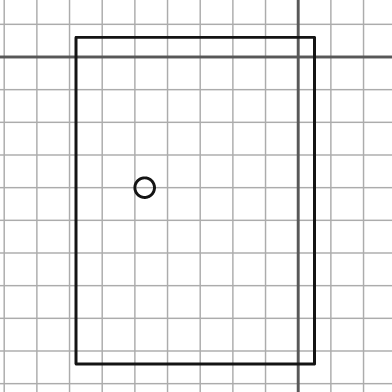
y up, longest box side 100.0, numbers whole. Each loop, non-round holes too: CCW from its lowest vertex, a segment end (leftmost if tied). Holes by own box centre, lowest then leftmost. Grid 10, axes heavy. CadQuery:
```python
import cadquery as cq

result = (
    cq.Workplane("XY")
    .moveTo(-68.0, -94.0)
    .lineTo(5.0, -94.0)
    .lineTo(5.0, 6.0)
    .lineTo(-68.0, 6.0)
    .close()
    .moveTo(-47.0, -40.0)
    .circle(3.0)
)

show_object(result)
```